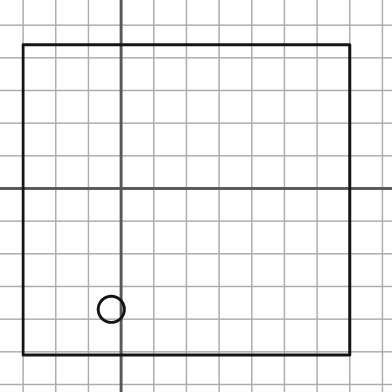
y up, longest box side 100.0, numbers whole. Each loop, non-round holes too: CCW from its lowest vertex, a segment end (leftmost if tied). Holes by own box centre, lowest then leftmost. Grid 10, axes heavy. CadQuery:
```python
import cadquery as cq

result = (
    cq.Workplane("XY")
    .moveTo(-30.0, -51.0)
    .lineTo(70.0, -51.0)
    .lineTo(70.0, 44.0)
    .lineTo(-30.0, 44.0)
    .close()
    .moveTo(-3.0, -37.0)
    .circle(4.0)
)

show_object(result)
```